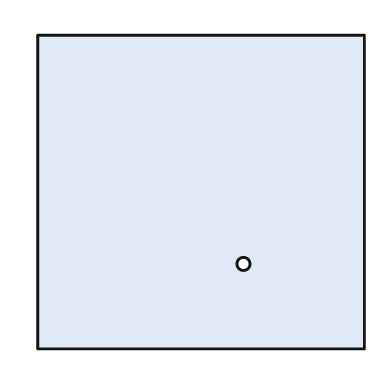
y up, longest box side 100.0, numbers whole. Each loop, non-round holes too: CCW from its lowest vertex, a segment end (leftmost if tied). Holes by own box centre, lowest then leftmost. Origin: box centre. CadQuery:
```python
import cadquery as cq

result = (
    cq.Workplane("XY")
    .moveTo(-50.0, -48.0)
    .lineTo(50.0, -48.0)
    .lineTo(50.0, 48.0)
    .lineTo(-50.0, 48.0)
    .close()
    .moveTo(13.0, -22.0)
    .circle(2.0)
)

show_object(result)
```